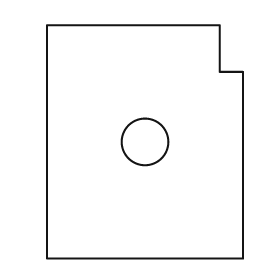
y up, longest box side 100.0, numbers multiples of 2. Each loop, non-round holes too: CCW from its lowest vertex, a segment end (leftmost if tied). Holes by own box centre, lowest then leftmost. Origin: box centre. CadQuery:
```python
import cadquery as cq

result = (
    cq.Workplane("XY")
    .moveTo(-42.0, -50.0)
    .lineTo(42.0, -50.0)
    .lineTo(42.0, 30.0)
    .lineTo(32.0, 30.0)
    .lineTo(32.0, 50.0)
    .lineTo(-42.0, 50.0)
    .close()
    .moveTo(0.0, 0.0)
    .circle(10.0)
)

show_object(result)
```